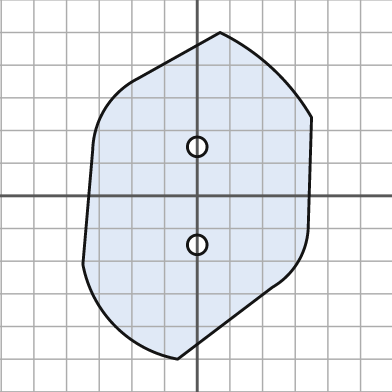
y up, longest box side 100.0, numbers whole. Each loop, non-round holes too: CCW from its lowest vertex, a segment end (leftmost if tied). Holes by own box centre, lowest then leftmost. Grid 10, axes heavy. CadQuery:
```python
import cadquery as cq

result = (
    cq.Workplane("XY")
    .moveTo(-6.0, -50.0)
    .lineTo(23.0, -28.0)
    .threePointArc((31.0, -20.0), (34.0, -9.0))
    .lineTo(35.0, 24.0)
    .threePointArc((23.0, 39.0), (7.0, 50.0))
    .lineTo(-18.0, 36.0)
    .threePointArc((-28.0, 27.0), (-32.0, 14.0))
    .lineTo(-35.0, -21.0)
    .threePointArc((-25.0, -40.0), (-6.0, -50.0))
    .close()
    .moveTo(0.0, -15.0)
    .circle(3.0)
    .moveTo(0.0, 15.0)
    .circle(3.0)
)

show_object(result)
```